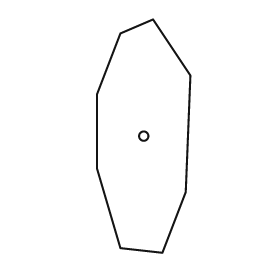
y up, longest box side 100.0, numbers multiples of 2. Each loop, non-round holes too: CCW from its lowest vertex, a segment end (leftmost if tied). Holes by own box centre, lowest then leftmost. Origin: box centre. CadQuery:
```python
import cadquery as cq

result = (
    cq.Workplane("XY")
    .moveTo(8.0, -50.0)
    .lineTo(18.0, -24.0)
    .lineTo(20.0, 26.0)
    .lineTo(4.0, 50.0)
    .lineTo(-10.0, 44.0)
    .lineTo(-20.0, 18.0)
    .lineTo(-20.0, -14.0)
    .lineTo(-10.0, -48.0)
    .close()
    .moveTo(0.0, 0.0)
    .circle(2.0)
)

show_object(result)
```